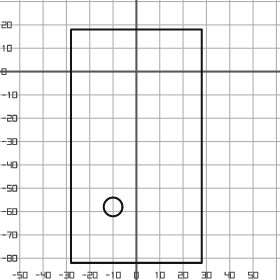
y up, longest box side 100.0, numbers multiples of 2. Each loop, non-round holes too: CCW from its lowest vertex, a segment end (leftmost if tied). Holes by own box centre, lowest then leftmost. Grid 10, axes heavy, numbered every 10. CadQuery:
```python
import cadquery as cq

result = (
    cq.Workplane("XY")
    .moveTo(-28.0, -82.0)
    .lineTo(28.0, -82.0)
    .lineTo(28.0, 18.0)
    .lineTo(-28.0, 18.0)
    .close()
    .moveTo(-10.0, -58.0)
    .circle(4.0)
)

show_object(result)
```